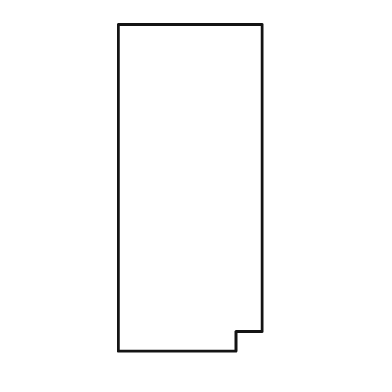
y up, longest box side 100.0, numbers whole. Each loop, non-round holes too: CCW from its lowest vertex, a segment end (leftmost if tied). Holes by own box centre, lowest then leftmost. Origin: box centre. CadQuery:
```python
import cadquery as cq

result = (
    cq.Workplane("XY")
    .moveTo(-22.0, -50.0)
    .lineTo(14.0, -50.0)
    .lineTo(14.0, -44.0)
    .lineTo(22.0, -44.0)
    .lineTo(22.0, 50.0)
    .lineTo(-22.0, 50.0)
    .close()
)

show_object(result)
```